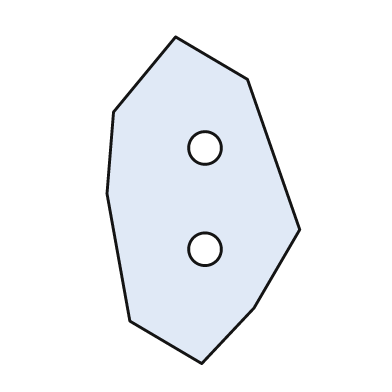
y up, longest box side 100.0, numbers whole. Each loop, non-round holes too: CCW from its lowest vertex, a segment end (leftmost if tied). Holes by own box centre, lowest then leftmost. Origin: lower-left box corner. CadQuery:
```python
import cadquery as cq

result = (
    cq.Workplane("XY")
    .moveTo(29.0, 0.0)
    .lineTo(45.0, 17.0)
    .lineTo(59.0, 41.0)
    .lineTo(43.0, 87.0)
    .lineTo(21.0, 100.0)
    .lineTo(2.0, 77.0)
    .lineTo(0.0, 52.0)
    .lineTo(7.0, 13.0)
    .close()
    .moveTo(30.0, 35.0)
    .circle(5.0)
    .moveTo(30.0, 66.0)
    .circle(5.0)
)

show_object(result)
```